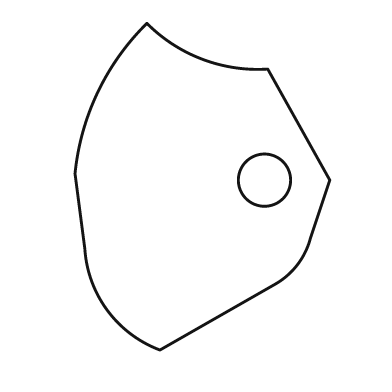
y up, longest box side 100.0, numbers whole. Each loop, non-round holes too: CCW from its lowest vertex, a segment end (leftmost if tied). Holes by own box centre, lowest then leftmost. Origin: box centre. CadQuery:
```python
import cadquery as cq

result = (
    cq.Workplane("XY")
    .moveTo(-13.0, -50.0)
    .lineTo(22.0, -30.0)
    .threePointArc((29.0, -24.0), (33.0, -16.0))
    .lineTo(39.0, 2.0)
    .lineTo(20.0, 36.0)
    .threePointArc((0.0, 39.0), (-17.0, 50.0))
    .threePointArc((-32.0, 29.0), (-39.0, 4.0))
    .lineTo(-36.0, -19.0)
    .threePointArc((-29.0, -38.0), (-13.0, -50.0))
    .close()
    .moveTo(19.0, 2.0)
    .circle(8.0)
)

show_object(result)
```